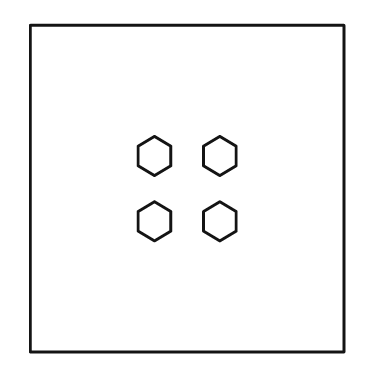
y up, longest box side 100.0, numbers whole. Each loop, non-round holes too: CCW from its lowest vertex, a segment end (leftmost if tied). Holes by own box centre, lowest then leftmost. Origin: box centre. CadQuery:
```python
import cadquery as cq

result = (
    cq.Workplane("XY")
    .moveTo(-48.0, -50.0)
    .lineTo(48.0, -50.0)
    .lineTo(48.0, 50.0)
    .lineTo(-48.0, 50.0)
    .close()
    .moveTo(-10.0, -16.0)
    .lineTo(-5.0, -13.0)
    .lineTo(-5.0, -7.0)
    .lineTo(-10.0, -4.0)
    .lineTo(-15.0, -7.0)
    .lineTo(-15.0, -13.0)
    .close()
    .moveTo(10.0, -16.0)
    .lineTo(15.0, -13.0)
    .lineTo(15.0, -7.0)
    .lineTo(10.0, -4.0)
    .lineTo(5.0, -7.0)
    .lineTo(5.0, -13.0)
    .close()
    .moveTo(-10.0, 4.0)
    .lineTo(-5.0, 7.0)
    .lineTo(-5.0, 13.0)
    .lineTo(-10.0, 16.0)
    .lineTo(-15.0, 13.0)
    .lineTo(-15.0, 7.0)
    .close()
    .moveTo(10.0, 4.0)
    .lineTo(15.0, 7.0)
    .lineTo(15.0, 13.0)
    .lineTo(10.0, 16.0)
    .lineTo(5.0, 13.0)
    .lineTo(5.0, 7.0)
    .close()
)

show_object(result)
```